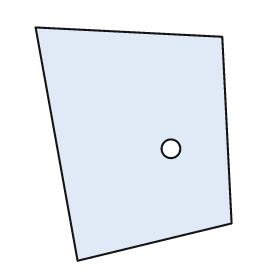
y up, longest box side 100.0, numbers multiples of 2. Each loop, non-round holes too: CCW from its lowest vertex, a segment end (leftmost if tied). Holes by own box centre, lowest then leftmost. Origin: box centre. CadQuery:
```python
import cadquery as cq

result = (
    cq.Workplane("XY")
    .moveTo(-24.0, -50.0)
    .lineTo(42.0, -34.0)
    .lineTo(38.0, 46.0)
    .lineTo(-42.0, 50.0)
    .close()
    .moveTo(16.0, -2.0)
    .circle(4.0)
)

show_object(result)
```